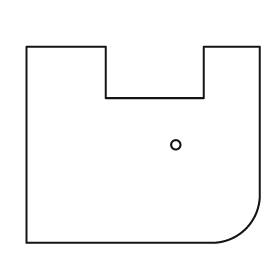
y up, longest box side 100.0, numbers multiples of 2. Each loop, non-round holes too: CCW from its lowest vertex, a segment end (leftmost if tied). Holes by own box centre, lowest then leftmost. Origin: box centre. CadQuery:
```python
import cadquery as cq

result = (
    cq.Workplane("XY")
    .moveTo(-50.0, -42.0)
    .lineTo(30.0, -42.0)
    .threePointArc((44.0, -36.0), (50.0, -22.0))
    .lineTo(50.0, 42.0)
    .lineTo(26.0, 42.0)
    .lineTo(26.0, 20.0)
    .lineTo(-16.0, 20.0)
    .lineTo(-16.0, 42.0)
    .lineTo(-50.0, 42.0)
    .close()
    .moveTo(14.0, 0.0)
    .circle(2.0)
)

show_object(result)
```